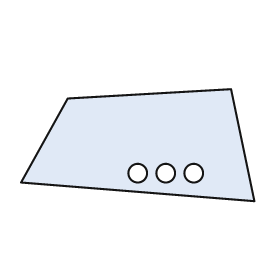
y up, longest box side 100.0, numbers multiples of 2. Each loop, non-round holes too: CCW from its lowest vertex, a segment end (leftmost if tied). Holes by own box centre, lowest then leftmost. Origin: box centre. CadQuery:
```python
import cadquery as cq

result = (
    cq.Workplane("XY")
    .moveTo(50.0, -24.0)
    .lineTo(40.0, 24.0)
    .lineTo(-30.0, 20.0)
    .lineTo(-50.0, -16.0)
    .close()
    .moveTo(0.0, -12.0)
    .circle(4.0)
    .moveTo(12.0, -12.0)
    .circle(4.0)
    .moveTo(24.0, -12.0)
    .circle(4.0)
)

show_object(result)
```